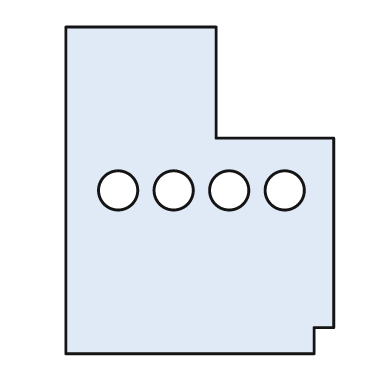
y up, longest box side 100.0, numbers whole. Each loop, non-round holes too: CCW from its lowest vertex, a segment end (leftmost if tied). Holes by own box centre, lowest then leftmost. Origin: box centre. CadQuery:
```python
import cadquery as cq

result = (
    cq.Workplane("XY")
    .moveTo(-41.0, -50.0)
    .lineTo(35.0, -50.0)
    .lineTo(35.0, -42.0)
    .lineTo(41.0, -42.0)
    .lineTo(41.0, 16.0)
    .lineTo(5.0, 16.0)
    .lineTo(5.0, 50.0)
    .lineTo(-41.0, 50.0)
    .close()
    .moveTo(-25.0, 0.0)
    .circle(6.0)
    .moveTo(-8.0, 0.0)
    .circle(6.0)
    .moveTo(9.0, 0.0)
    .circle(6.0)
    .moveTo(26.0, 0.0)
    .circle(6.0)
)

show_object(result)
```